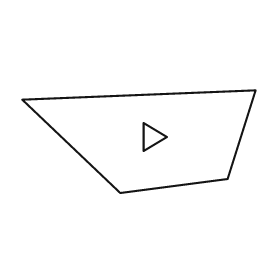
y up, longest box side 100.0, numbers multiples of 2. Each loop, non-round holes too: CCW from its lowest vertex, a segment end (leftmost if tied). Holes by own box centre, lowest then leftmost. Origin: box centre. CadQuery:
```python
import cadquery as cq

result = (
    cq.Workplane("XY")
    .moveTo(-8.0, -22.0)
    .lineTo(38.0, -16.0)
    .lineTo(50.0, 22.0)
    .lineTo(-50.0, 18.0)
    .close()
    .moveTo(2.0, -4.0)
    .lineTo(12.0, 2.0)
    .lineTo(2.0, 8.0)
    .close()
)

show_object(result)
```